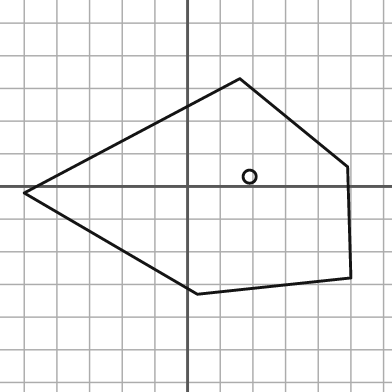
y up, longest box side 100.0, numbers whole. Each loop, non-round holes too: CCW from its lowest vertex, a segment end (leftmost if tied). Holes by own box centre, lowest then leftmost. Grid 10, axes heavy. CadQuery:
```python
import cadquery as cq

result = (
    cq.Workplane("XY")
    .moveTo(3.0, -33.0)
    .lineTo(50.0, -28.0)
    .lineTo(49.0, 6.0)
    .lineTo(16.0, 33.0)
    .lineTo(-50.0, -2.0)
    .close()
    .moveTo(19.0, 3.0)
    .circle(2.0)
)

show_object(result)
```